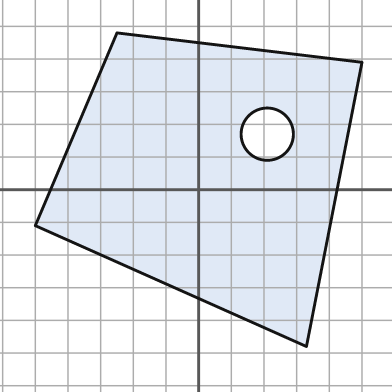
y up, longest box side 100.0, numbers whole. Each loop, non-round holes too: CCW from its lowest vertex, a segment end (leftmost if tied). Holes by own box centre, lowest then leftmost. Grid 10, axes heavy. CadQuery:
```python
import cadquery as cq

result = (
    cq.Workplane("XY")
    .moveTo(33.0, -48.0)
    .lineTo(50.0, 39.0)
    .lineTo(-25.0, 48.0)
    .lineTo(-50.0, -11.0)
    .close()
    .moveTo(21.0, 17.0)
    .circle(8.0)
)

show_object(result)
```